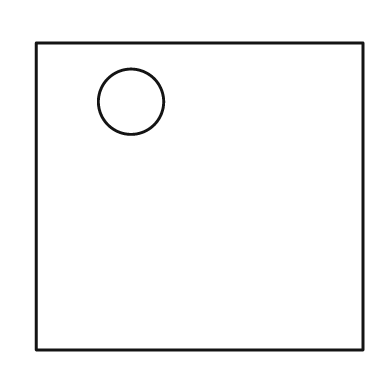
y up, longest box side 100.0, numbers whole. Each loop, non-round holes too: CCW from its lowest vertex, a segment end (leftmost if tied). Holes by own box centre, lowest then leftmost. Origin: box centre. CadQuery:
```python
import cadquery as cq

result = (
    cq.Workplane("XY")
    .moveTo(-50.0, -47.0)
    .lineTo(50.0, -47.0)
    .lineTo(50.0, 47.0)
    .lineTo(-50.0, 47.0)
    .close()
    .moveTo(-21.0, 29.0)
    .circle(10.0)
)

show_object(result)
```